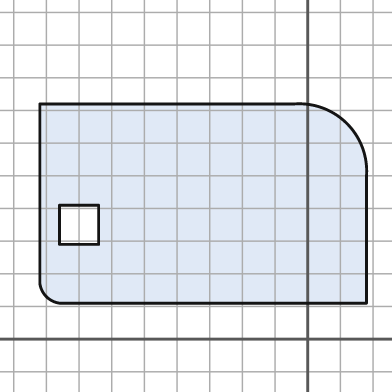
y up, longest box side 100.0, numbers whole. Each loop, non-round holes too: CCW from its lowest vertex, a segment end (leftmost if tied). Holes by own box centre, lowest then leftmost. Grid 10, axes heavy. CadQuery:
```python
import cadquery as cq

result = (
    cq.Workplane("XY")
    .moveTo(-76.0, 11.0)
    .lineTo(18.0, 11.0)
    .lineTo(18.0, 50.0)
    .threePointArc((12.0, 66.0), (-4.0, 72.0))
    .lineTo(-82.0, 72.0)
    .lineTo(-82.0, 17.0)
    .threePointArc((-80.0, 13.0), (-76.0, 11.0))
    .close()
    .moveTo(-76.0, 29.0)
    .lineTo(-64.0, 29.0)
    .lineTo(-64.0, 41.0)
    .lineTo(-76.0, 41.0)
    .close()
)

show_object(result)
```